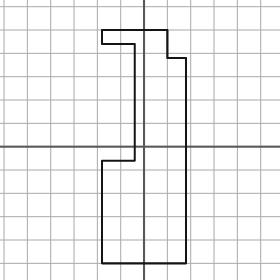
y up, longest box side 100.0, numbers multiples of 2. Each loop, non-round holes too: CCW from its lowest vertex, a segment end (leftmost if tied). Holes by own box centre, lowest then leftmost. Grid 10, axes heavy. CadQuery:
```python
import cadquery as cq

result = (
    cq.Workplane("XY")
    .moveTo(-18.0, -50.0)
    .lineTo(18.0, -50.0)
    .lineTo(18.0, 38.0)
    .lineTo(10.0, 38.0)
    .lineTo(10.0, 50.0)
    .lineTo(-18.0, 50.0)
    .lineTo(-18.0, 44.0)
    .lineTo(-4.0, 44.0)
    .lineTo(-4.0, -6.0)
    .lineTo(-18.0, -6.0)
    .close()
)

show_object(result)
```